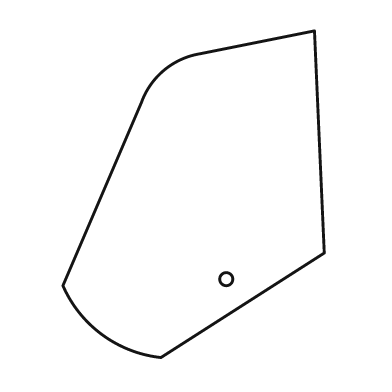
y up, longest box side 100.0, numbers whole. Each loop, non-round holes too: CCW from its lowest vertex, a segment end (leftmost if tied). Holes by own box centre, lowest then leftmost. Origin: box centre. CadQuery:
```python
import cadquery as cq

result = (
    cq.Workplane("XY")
    .moveTo(-10.0, -50.0)
    .lineTo(40.0, -18.0)
    .lineTo(37.0, 50.0)
    .lineTo(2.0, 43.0)
    .threePointArc((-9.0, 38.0), (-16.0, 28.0))
    .lineTo(-40.0, -28.0)
    .threePointArc((-28.0, -43.0), (-10.0, -50.0))
    .close()
    .moveTo(10.0, -26.0)
    .circle(2.0)
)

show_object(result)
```